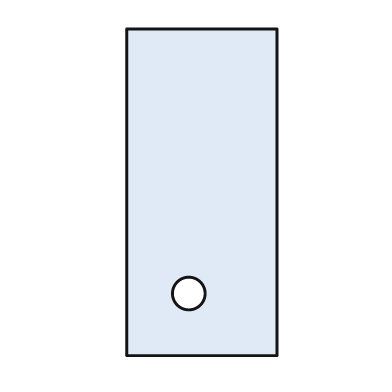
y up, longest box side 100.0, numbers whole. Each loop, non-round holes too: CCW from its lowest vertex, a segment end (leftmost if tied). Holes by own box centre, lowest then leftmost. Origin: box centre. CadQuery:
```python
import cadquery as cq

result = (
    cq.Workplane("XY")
    .moveTo(-23.0, -50.0)
    .lineTo(23.0, -50.0)
    .lineTo(23.0, 50.0)
    .lineTo(-23.0, 50.0)
    .close()
    .moveTo(-4.0, -31.0)
    .circle(5.0)
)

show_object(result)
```